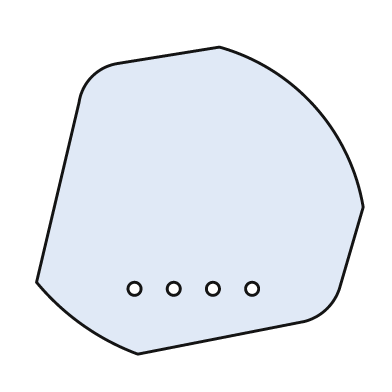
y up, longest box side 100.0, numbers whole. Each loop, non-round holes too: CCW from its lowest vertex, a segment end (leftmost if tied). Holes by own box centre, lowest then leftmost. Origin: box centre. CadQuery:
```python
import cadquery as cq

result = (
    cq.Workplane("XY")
    .moveTo(-19.0, -47.0)
    .lineTo(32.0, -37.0)
    .threePointArc((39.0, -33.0), (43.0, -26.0))
    .lineTo(50.0, -2.0)
    .threePointArc((35.0, 29.0), (6.0, 47.0))
    .lineTo(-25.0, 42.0)
    .threePointArc((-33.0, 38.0), (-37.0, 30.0))
    .lineTo(-50.0, -25.0)
    .threePointArc((-36.0, -38.0), (-19.0, -47.0))
    .close()
    .moveTo(-20.0, -27.0)
    .circle(2.0)
    .moveTo(-8.0, -27.0)
    .circle(2.0)
    .moveTo(4.0, -27.0)
    .circle(2.0)
    .moveTo(16.0, -27.0)
    .circle(2.0)
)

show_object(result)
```